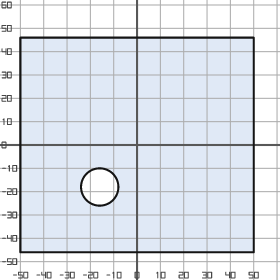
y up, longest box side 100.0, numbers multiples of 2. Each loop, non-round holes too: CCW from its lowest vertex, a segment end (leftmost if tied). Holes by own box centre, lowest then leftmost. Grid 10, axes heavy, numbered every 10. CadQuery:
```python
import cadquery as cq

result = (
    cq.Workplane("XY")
    .moveTo(-50.0, -46.0)
    .lineTo(50.0, -46.0)
    .lineTo(50.0, 46.0)
    .lineTo(-50.0, 46.0)
    .close()
    .moveTo(-16.0, -18.0)
    .circle(8.0)
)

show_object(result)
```